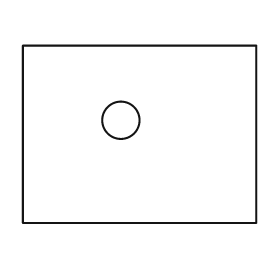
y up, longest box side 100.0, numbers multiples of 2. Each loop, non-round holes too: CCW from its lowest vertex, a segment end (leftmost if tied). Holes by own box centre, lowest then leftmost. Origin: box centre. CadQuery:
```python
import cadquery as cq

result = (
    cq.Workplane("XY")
    .moveTo(-50.0, -38.0)
    .lineTo(50.0, -38.0)
    .lineTo(50.0, 38.0)
    .lineTo(-50.0, 38.0)
    .close()
    .moveTo(-8.0, 6.0)
    .circle(8.0)
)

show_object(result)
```